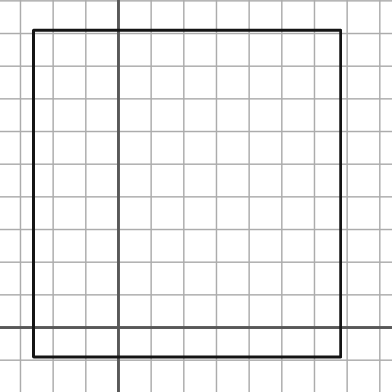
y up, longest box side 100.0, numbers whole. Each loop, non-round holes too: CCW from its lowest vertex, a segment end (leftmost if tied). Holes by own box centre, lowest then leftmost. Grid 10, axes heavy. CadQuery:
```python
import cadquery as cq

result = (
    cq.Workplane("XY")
    .moveTo(-26.0, -9.0)
    .lineTo(68.0, -9.0)
    .lineTo(68.0, 91.0)
    .lineTo(-26.0, 91.0)
    .close()
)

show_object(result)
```